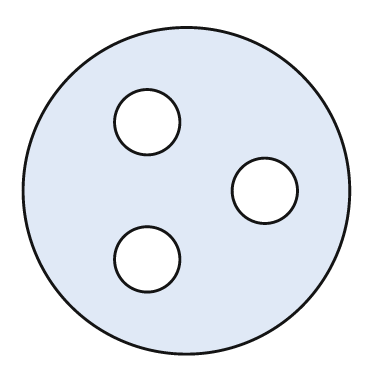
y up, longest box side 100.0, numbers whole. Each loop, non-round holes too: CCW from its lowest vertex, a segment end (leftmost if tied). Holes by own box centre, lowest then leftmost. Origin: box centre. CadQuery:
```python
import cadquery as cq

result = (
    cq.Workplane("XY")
    .moveTo(0.0, 0.0)
    .circle(50.0)
    .moveTo(-12.0, -21.0)
    .circle(10.0)
    .moveTo(24.0, 0.0)
    .circle(10.0)
    .moveTo(-12.0, 21.0)
    .circle(10.0)
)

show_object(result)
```